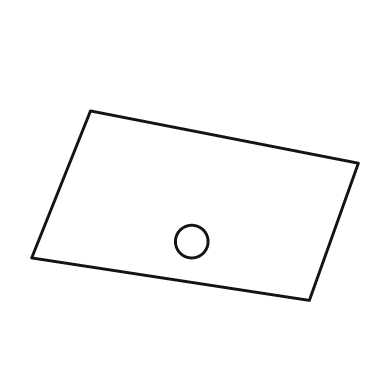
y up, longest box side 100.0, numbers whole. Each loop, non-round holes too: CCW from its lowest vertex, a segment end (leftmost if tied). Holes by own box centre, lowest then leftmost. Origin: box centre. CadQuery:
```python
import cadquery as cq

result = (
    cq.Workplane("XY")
    .moveTo(35.0, -29.0)
    .lineTo(50.0, 13.0)
    .lineTo(-32.0, 29.0)
    .lineTo(-50.0, -16.0)
    .close()
    .moveTo(-1.0, -11.0)
    .circle(5.0)
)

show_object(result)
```